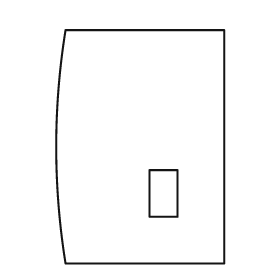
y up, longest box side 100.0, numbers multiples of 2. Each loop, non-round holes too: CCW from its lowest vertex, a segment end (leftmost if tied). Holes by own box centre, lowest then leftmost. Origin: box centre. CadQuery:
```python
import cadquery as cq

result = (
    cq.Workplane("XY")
    .moveTo(-32.0, -50.0)
    .lineTo(36.0, -50.0)
    .lineTo(36.0, 50.0)
    .lineTo(-32.0, 50.0)
    .threePointArc((-36.0, 0.0), (-32.0, -50.0))
    .close()
    .moveTo(4.0, -30.0)
    .lineTo(16.0, -30.0)
    .lineTo(16.0, -10.0)
    .lineTo(4.0, -10.0)
    .close()
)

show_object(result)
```